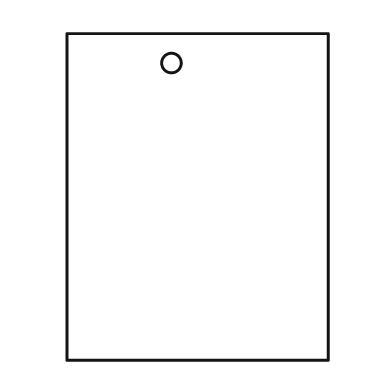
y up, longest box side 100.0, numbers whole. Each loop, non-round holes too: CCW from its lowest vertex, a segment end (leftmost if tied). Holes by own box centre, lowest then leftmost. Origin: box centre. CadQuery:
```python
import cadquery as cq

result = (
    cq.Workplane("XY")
    .moveTo(-40.0, -50.0)
    .lineTo(40.0, -50.0)
    .lineTo(40.0, 50.0)
    .lineTo(-40.0, 50.0)
    .close()
    .moveTo(-8.0, 41.0)
    .circle(3.0)
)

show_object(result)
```